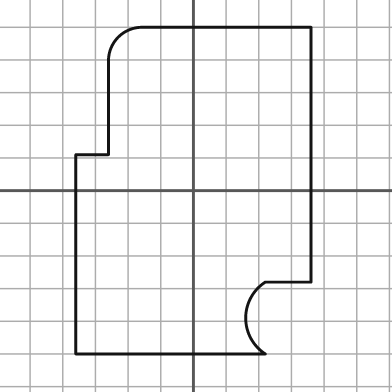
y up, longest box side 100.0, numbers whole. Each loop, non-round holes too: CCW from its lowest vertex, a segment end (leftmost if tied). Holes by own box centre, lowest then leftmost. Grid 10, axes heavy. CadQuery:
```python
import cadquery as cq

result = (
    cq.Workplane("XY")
    .moveTo(-36.0, -50.0)
    .lineTo(22.0, -50.0)
    .threePointArc((16.0, -39.0), (22.0, -28.0))
    .lineTo(36.0, -28.0)
    .lineTo(36.0, 50.0)
    .lineTo(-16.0, 50.0)
    .threePointArc((-23.0, 47.0), (-26.0, 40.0))
    .lineTo(-26.0, 11.0)
    .lineTo(-36.0, 11.0)
    .close()
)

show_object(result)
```